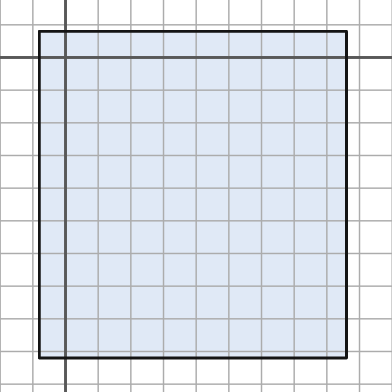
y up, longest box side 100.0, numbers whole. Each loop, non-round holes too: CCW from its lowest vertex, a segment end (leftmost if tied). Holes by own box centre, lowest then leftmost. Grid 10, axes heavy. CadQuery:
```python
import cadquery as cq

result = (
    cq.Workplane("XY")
    .moveTo(-8.0, -92.0)
    .lineTo(86.0, -92.0)
    .lineTo(86.0, 8.0)
    .lineTo(-8.0, 8.0)
    .close()
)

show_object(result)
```